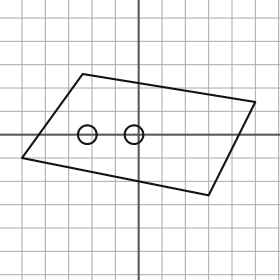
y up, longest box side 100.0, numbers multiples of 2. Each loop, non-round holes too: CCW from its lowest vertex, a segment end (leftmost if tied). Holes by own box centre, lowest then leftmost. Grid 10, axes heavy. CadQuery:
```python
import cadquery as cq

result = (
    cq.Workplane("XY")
    .moveTo(30.0, -26.0)
    .lineTo(50.0, 14.0)
    .lineTo(-24.0, 26.0)
    .lineTo(-50.0, -10.0)
    .close()
    .moveTo(-22.0, 0.0)
    .circle(4.0)
    .moveTo(-2.0, 0.0)
    .circle(4.0)
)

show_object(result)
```